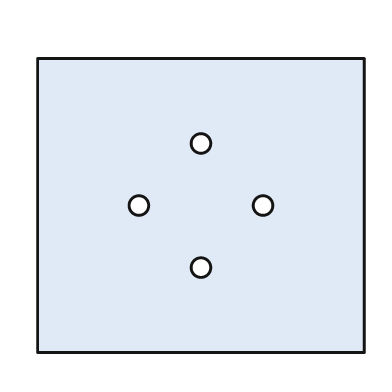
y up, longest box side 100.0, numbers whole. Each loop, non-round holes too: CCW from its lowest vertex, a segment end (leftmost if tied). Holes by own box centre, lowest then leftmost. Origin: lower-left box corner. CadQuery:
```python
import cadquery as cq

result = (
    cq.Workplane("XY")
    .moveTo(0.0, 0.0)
    .lineTo(100.0, 0.0)
    .lineTo(100.0, 90.0)
    .lineTo(0.0, 90.0)
    .close()
    .moveTo(50.0, 26.0)
    .circle(3.0)
    .moveTo(31.0, 45.0)
    .circle(3.0)
    .moveTo(69.0, 45.0)
    .circle(3.0)
    .moveTo(50.0, 64.0)
    .circle(3.0)
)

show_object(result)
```